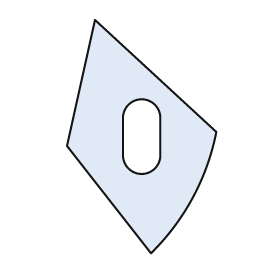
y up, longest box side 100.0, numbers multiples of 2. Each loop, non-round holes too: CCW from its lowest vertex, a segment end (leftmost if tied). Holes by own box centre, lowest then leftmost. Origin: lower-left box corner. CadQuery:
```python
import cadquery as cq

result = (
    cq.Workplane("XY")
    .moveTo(36.0, 0.0)
    .threePointArc((54.0, 24.0), (64.0, 52.0))
    .lineTo(12.0, 100.0)
    .lineTo(0.0, 46.0)
    .close()
    .moveTo(24.0, 42.0)
    .threePointArc((32.0, 34.0), (40.0, 42.0))
    .lineTo(40.0, 58.0)
    .threePointArc((32.0, 66.0), (24.0, 58.0))
    .close()
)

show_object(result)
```